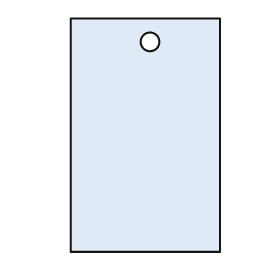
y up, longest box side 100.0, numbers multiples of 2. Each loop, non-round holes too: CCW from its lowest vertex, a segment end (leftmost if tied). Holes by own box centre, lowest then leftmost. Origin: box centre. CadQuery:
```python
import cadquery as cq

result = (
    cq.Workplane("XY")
    .moveTo(-32.0, -50.0)
    .lineTo(32.0, -50.0)
    .lineTo(32.0, 50.0)
    .lineTo(-32.0, 50.0)
    .close()
    .moveTo(2.0, 40.0)
    .circle(4.0)
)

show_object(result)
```